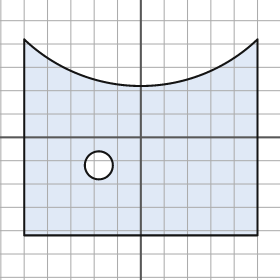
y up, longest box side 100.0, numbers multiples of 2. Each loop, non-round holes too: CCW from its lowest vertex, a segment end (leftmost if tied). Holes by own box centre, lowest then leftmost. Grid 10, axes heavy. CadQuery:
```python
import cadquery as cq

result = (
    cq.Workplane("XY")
    .moveTo(-50.0, -42.0)
    .lineTo(50.0, -42.0)
    .lineTo(50.0, 42.0)
    .threePointArc((0.0, 22.0), (-50.0, 42.0))
    .close()
    .moveTo(-18.0, -12.0)
    .circle(6.0)
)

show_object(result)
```